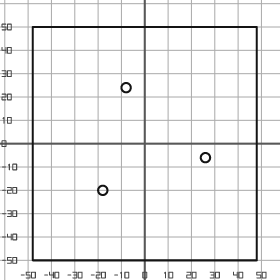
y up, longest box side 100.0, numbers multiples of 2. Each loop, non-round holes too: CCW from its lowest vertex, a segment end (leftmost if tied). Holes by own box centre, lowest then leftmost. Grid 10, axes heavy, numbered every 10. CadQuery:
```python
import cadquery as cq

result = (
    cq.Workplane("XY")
    .moveTo(-48.0, -50.0)
    .lineTo(48.0, -50.0)
    .lineTo(48.0, 50.0)
    .lineTo(-48.0, 50.0)
    .close()
    .moveTo(-18.0, -20.0)
    .circle(2.0)
    .moveTo(26.0, -6.0)
    .circle(2.0)
    .moveTo(-8.0, 24.0)
    .circle(2.0)
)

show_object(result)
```